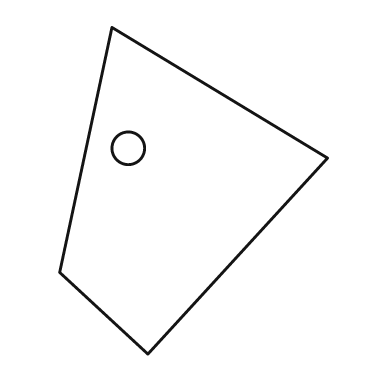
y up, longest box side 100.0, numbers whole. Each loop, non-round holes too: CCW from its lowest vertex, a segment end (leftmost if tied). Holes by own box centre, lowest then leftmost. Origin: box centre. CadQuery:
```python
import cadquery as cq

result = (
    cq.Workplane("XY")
    .moveTo(-14.0, -50.0)
    .lineTo(41.0, 10.0)
    .lineTo(-25.0, 50.0)
    .lineTo(-41.0, -25.0)
    .close()
    .moveTo(-20.0, 13.0)
    .circle(5.0)
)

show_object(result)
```